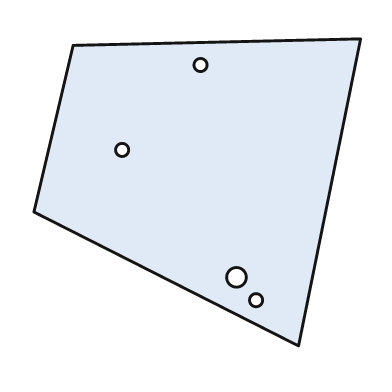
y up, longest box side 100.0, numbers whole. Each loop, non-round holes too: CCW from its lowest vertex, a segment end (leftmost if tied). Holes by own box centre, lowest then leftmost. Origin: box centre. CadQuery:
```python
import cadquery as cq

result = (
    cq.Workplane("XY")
    .moveTo(31.0, -47.0)
    .lineTo(50.0, 47.0)
    .lineTo(-38.0, 45.0)
    .lineTo(-50.0, -6.0)
    .close()
    .moveTo(18.0, -33.0)
    .circle(2.0)
    .moveTo(12.0, -26.0)
    .circle(3.0)
    .moveTo(-23.0, 13.0)
    .circle(2.0)
    .moveTo(1.0, 39.0)
    .circle(2.0)
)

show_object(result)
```